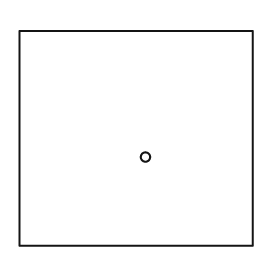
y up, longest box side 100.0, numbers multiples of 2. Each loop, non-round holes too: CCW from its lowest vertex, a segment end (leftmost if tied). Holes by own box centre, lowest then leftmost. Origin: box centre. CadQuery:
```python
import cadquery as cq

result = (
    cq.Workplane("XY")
    .moveTo(-50.0, -46.0)
    .lineTo(50.0, -46.0)
    .lineTo(50.0, 46.0)
    .lineTo(-50.0, 46.0)
    .close()
    .moveTo(4.0, -8.0)
    .circle(2.0)
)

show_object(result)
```